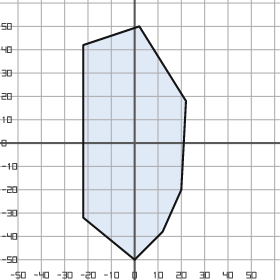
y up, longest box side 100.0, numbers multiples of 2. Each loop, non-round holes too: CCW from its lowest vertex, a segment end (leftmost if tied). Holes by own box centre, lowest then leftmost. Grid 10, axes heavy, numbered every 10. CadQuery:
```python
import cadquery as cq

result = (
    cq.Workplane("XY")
    .moveTo(0.0, -50.0)
    .lineTo(12.0, -38.0)
    .lineTo(20.0, -20.0)
    .lineTo(22.0, 18.0)
    .lineTo(2.0, 50.0)
    .lineTo(-22.0, 42.0)
    .lineTo(-22.0, -32.0)
    .close()
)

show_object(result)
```